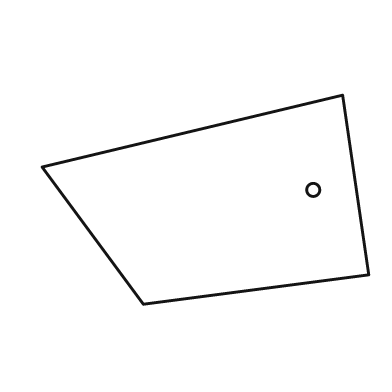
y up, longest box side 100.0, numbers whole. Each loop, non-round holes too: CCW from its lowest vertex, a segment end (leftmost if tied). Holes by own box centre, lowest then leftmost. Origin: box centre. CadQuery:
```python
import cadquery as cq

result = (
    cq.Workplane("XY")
    .moveTo(-19.0, -32.0)
    .lineTo(50.0, -23.0)
    .lineTo(42.0, 32.0)
    .lineTo(-50.0, 10.0)
    .close()
    .moveTo(33.0, 3.0)
    .circle(2.0)
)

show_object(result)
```